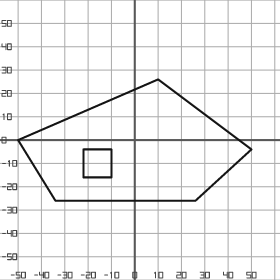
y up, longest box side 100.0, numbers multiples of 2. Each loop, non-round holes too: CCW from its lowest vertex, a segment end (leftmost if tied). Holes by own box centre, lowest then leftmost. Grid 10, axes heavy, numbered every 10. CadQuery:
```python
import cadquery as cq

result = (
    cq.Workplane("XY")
    .moveTo(-34.0, -26.0)
    .lineTo(26.0, -26.0)
    .lineTo(50.0, -4.0)
    .lineTo(10.0, 26.0)
    .lineTo(-50.0, 0.0)
    .close()
    .moveTo(-22.0, -16.0)
    .lineTo(-10.0, -16.0)
    .lineTo(-10.0, -4.0)
    .lineTo(-22.0, -4.0)
    .close()
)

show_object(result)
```